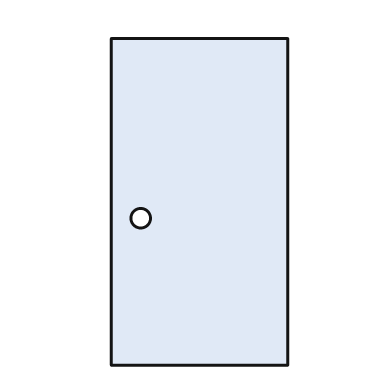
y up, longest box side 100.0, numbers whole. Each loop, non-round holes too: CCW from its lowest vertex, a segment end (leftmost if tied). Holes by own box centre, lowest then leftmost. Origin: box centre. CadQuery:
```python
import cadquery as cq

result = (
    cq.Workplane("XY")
    .moveTo(-27.0, -50.0)
    .lineTo(27.0, -50.0)
    .lineTo(27.0, 50.0)
    .lineTo(-27.0, 50.0)
    .close()
    .moveTo(-18.0, -5.0)
    .circle(3.0)
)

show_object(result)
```